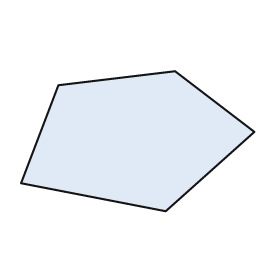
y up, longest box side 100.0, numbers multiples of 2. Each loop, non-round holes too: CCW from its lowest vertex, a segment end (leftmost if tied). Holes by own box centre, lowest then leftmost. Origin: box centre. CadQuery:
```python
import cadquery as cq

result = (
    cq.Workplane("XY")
    .moveTo(12.0, -30.0)
    .lineTo(50.0, 4.0)
    .lineTo(16.0, 30.0)
    .lineTo(-34.0, 24.0)
    .lineTo(-50.0, -18.0)
    .close()
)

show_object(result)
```